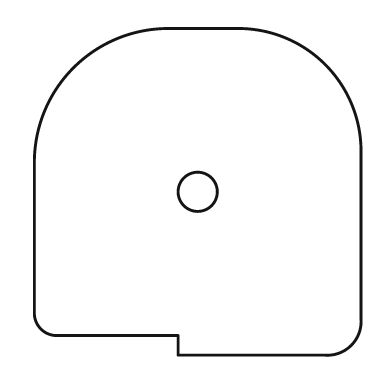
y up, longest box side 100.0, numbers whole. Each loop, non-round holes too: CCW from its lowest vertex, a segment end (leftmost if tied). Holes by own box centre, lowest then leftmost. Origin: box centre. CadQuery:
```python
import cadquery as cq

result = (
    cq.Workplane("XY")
    .moveTo(-6.0, -50.0)
    .lineTo(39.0, -50.0)
    .threePointArc((47.0, -47.0), (50.0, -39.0))
    .lineTo(50.0, 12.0)
    .threePointArc((39.0, 39.0), (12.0, 50.0))
    .lineTo(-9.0, 50.0)
    .threePointArc((-38.0, 38.0), (-50.0, 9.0))
    .lineTo(-50.0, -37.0)
    .threePointArc((-48.0, -42.0), (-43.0, -44.0))
    .lineTo(-6.0, -44.0)
    .close()
    .moveTo(0.0, 0.0)
    .circle(6.0)
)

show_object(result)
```